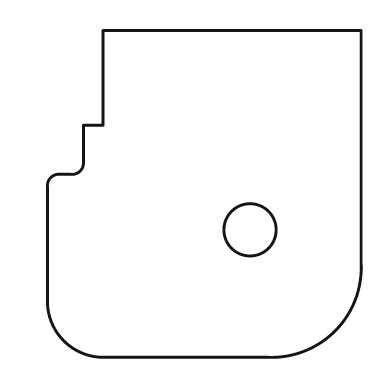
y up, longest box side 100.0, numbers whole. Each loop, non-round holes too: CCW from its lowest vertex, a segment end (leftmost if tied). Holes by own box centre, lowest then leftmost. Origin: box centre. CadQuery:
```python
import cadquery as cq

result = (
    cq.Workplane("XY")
    .moveTo(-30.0, -50.0)
    .lineTo(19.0, -50.0)
    .threePointArc((40.0, -42.0), (48.0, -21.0))
    .lineTo(48.0, 50.0)
    .lineTo(-31.0, 50.0)
    .lineTo(-31.0, 21.0)
    .lineTo(-37.0, 21.0)
    .lineTo(-37.0, 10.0)
    .threePointArc((-38.0, 7.0), (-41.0, 6.0))
    .lineTo(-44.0, 6.0)
    .threePointArc((-47.0, 5.0), (-48.0, 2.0))
    .lineTo(-48.0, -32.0)
    .threePointArc((-43.0, -45.0), (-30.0, -50.0))
    .close()
    .moveTo(14.0, -11.0)
    .circle(8.0)
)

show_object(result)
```